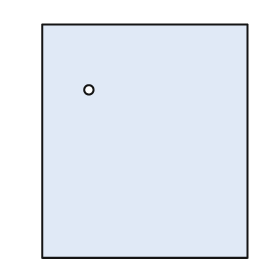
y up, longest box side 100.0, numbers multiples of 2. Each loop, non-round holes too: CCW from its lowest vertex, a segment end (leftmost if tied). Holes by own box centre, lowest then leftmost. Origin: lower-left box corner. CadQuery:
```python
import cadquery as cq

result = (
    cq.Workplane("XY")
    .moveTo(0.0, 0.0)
    .lineTo(88.0, 0.0)
    .lineTo(88.0, 100.0)
    .lineTo(0.0, 100.0)
    .close()
    .moveTo(20.0, 72.0)
    .circle(2.0)
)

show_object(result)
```